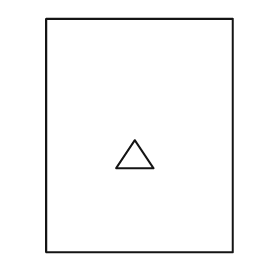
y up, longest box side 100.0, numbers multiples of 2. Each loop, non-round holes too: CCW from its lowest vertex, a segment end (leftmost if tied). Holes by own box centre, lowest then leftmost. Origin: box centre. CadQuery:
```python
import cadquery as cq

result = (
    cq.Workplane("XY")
    .moveTo(-40.0, -50.0)
    .lineTo(40.0, -50.0)
    .lineTo(40.0, 50.0)
    .lineTo(-40.0, 50.0)
    .close()
    .moveTo(-10.0, -14.0)
    .lineTo(6.0, -14.0)
    .lineTo(-2.0, -2.0)
    .close()
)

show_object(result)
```